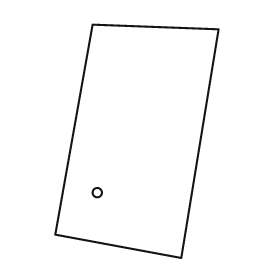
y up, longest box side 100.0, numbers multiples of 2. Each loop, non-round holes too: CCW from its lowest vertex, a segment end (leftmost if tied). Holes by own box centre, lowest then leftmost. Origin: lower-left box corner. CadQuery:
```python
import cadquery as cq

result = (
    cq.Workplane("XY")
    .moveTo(54.0, 0.0)
    .lineTo(70.0, 98.0)
    .lineTo(16.0, 100.0)
    .lineTo(0.0, 10.0)
    .close()
    .moveTo(18.0, 28.0)
    .circle(2.0)
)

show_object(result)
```